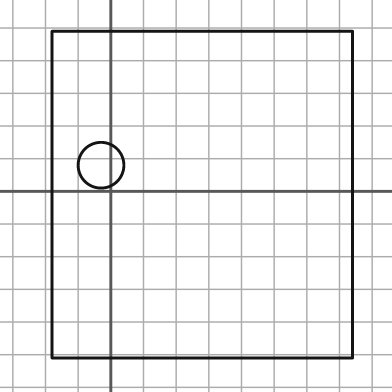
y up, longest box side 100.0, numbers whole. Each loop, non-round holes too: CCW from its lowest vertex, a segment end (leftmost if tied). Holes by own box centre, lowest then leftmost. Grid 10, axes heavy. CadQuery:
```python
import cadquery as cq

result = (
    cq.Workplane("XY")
    .moveTo(-18.0, -51.0)
    .lineTo(74.0, -51.0)
    .lineTo(74.0, 49.0)
    .lineTo(-18.0, 49.0)
    .close()
    .moveTo(-3.0, 8.0)
    .circle(7.0)
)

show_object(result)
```